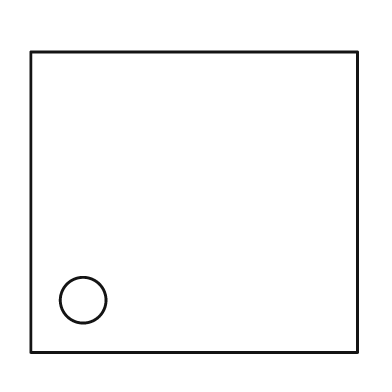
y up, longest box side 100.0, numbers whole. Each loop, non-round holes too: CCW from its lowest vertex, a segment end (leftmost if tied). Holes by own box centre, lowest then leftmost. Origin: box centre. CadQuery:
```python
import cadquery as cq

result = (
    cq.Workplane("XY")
    .moveTo(-50.0, -46.0)
    .lineTo(50.0, -46.0)
    .lineTo(50.0, 46.0)
    .lineTo(-50.0, 46.0)
    .close()
    .moveTo(-34.0, -30.0)
    .circle(7.0)
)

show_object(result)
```